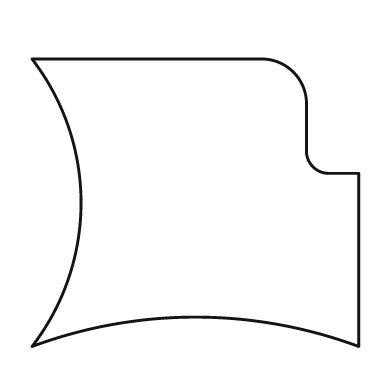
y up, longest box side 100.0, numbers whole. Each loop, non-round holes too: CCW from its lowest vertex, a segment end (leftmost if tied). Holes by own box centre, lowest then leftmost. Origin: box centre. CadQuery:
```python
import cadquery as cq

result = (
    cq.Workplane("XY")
    .moveTo(-50.0, -44.0)
    .threePointArc((0.0, -35.0), (50.0, -44.0))
    .lineTo(50.0, 9.0)
    .lineTo(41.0, 9.0)
    .threePointArc((36.0, 11.0), (34.0, 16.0))
    .lineTo(34.0, 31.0)
    .threePointArc((30.0, 40.0), (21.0, 44.0))
    .lineTo(-50.0, 44.0)
    .threePointArc((-35.0, 0.0), (-50.0, -44.0))
    .close()
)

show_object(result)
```